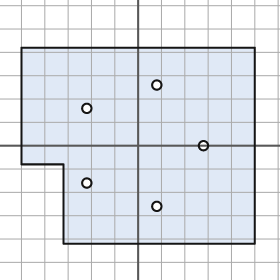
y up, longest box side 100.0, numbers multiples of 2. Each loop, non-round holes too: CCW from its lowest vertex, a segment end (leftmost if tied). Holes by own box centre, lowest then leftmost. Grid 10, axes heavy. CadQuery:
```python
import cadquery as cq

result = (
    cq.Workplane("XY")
    .moveTo(-32.0, -42.0)
    .lineTo(50.0, -42.0)
    .lineTo(50.0, 42.0)
    .lineTo(-50.0, 42.0)
    .lineTo(-50.0, -8.0)
    .lineTo(-32.0, -8.0)
    .close()
    .moveTo(8.0, -26.0)
    .circle(2.0)
    .moveTo(-22.0, -16.0)
    .circle(2.0)
    .moveTo(28.0, 0.0)
    .circle(2.0)
    .moveTo(-22.0, 16.0)
    .circle(2.0)
    .moveTo(8.0, 26.0)
    .circle(2.0)
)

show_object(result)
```